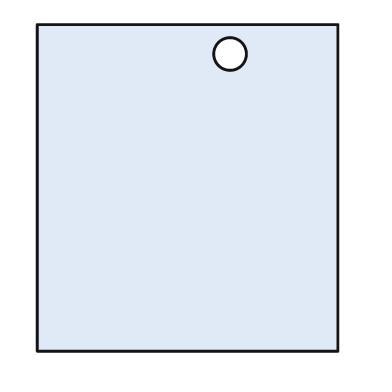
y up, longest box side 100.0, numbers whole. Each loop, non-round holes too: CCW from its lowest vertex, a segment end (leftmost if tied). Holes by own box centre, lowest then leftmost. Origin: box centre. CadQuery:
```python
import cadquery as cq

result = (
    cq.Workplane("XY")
    .moveTo(-46.0, -50.0)
    .lineTo(46.0, -50.0)
    .lineTo(46.0, 50.0)
    .lineTo(-46.0, 50.0)
    .close()
    .moveTo(13.0, 41.0)
    .circle(5.0)
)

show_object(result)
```